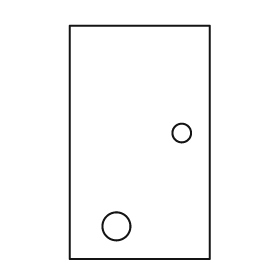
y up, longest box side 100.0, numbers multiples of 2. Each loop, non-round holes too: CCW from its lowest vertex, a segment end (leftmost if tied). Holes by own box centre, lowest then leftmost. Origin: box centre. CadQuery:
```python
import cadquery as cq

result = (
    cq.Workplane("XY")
    .moveTo(-30.0, -50.0)
    .lineTo(30.0, -50.0)
    .lineTo(30.0, 50.0)
    .lineTo(-30.0, 50.0)
    .close()
    .moveTo(-10.0, -36.0)
    .circle(6.0)
    .moveTo(18.0, 4.0)
    .circle(4.0)
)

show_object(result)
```